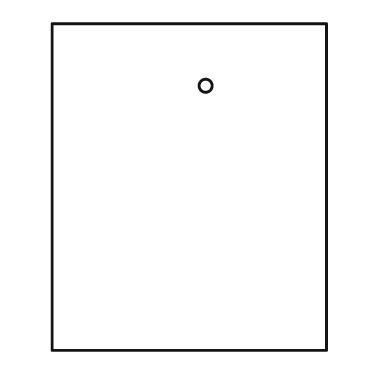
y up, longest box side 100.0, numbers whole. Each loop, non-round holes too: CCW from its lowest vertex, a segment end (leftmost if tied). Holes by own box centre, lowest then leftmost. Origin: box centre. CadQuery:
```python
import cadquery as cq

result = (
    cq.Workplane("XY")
    .moveTo(-42.0, -50.0)
    .lineTo(42.0, -50.0)
    .lineTo(42.0, 50.0)
    .lineTo(-42.0, 50.0)
    .close()
    .moveTo(5.0, 31.0)
    .circle(2.0)
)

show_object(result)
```